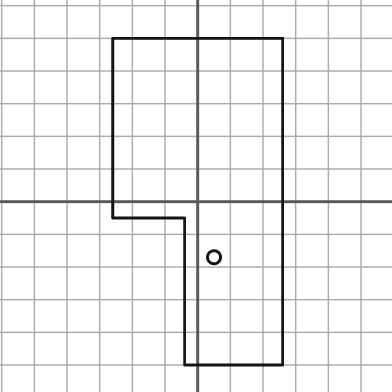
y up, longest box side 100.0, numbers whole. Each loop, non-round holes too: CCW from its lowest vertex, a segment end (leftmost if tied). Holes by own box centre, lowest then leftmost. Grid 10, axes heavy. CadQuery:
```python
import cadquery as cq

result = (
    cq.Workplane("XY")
    .moveTo(-4.0, -50.0)
    .lineTo(26.0, -50.0)
    .lineTo(26.0, 50.0)
    .lineTo(-26.0, 50.0)
    .lineTo(-26.0, -5.0)
    .lineTo(-4.0, -5.0)
    .close()
    .moveTo(5.0, -17.0)
    .circle(2.0)
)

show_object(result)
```